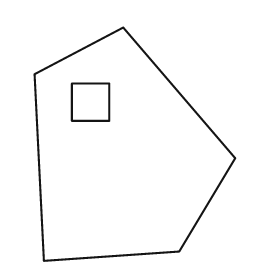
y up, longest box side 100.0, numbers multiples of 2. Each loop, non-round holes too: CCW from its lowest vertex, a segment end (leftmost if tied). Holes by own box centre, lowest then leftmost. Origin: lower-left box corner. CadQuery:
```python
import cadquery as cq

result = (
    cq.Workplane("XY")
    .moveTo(4.0, 0.0)
    .lineTo(62.0, 4.0)
    .lineTo(86.0, 44.0)
    .lineTo(38.0, 100.0)
    .lineTo(0.0, 80.0)
    .close()
    .moveTo(16.0, 60.0)
    .lineTo(32.0, 60.0)
    .lineTo(32.0, 76.0)
    .lineTo(16.0, 76.0)
    .close()
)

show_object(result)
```